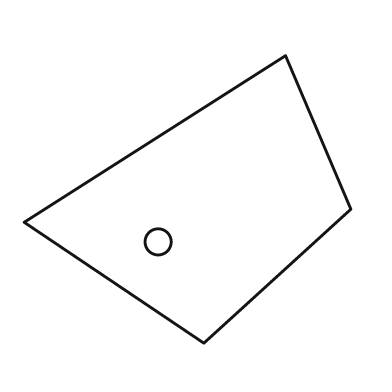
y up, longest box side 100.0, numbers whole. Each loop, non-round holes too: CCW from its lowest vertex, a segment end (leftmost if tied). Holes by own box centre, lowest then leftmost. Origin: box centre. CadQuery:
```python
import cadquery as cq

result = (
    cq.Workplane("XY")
    .moveTo(5.0, -44.0)
    .lineTo(50.0, -3.0)
    .lineTo(30.0, 44.0)
    .lineTo(-50.0, -7.0)
    .close()
    .moveTo(-9.0, -13.0)
    .circle(4.0)
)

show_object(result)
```